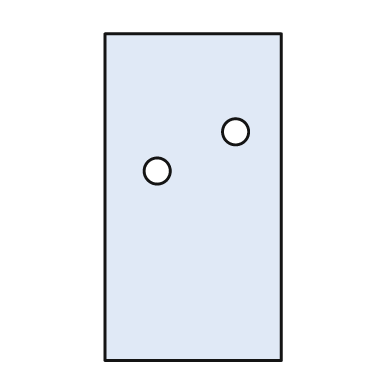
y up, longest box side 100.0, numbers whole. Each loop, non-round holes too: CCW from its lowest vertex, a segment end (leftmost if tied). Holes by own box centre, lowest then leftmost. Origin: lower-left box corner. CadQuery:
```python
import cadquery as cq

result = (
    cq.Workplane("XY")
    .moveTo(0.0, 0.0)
    .lineTo(54.0, 0.0)
    .lineTo(54.0, 100.0)
    .lineTo(0.0, 100.0)
    .close()
    .moveTo(16.0, 58.0)
    .circle(4.0)
    .moveTo(40.0, 70.0)
    .circle(4.0)
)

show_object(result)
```